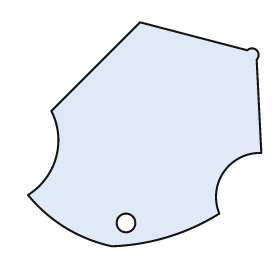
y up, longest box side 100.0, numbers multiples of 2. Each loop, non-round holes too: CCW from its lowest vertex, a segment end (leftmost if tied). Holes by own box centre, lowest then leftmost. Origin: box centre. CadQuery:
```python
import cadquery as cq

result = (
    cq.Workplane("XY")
    .moveTo(-14.0, -48.0)
    .threePointArc((10.0, -44.0), (32.0, -34.0))
    .threePointArc((34.0, -16.0), (50.0, -8.0))
    .lineTo(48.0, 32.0)
    .threePointArc((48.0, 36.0), (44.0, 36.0))
    .lineTo(-2.0, 48.0)
    .lineTo(-40.0, 10.0)
    .threePointArc((-38.0, -10.0), (-50.0, -26.0))
    .threePointArc((-34.0, -40.0), (-14.0, -48.0))
    .close()
    .moveTo(-8.0, -38.0)
    .circle(4.0)
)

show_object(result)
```